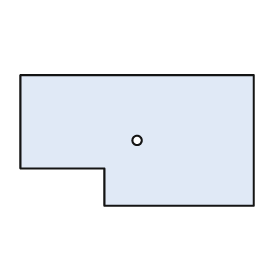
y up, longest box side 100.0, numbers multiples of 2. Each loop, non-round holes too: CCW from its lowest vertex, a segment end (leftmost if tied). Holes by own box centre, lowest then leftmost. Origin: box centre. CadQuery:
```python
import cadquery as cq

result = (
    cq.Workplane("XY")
    .moveTo(-14.0, -28.0)
    .lineTo(50.0, -28.0)
    .lineTo(50.0, 28.0)
    .lineTo(-50.0, 28.0)
    .lineTo(-50.0, -12.0)
    .lineTo(-14.0, -12.0)
    .close()
    .moveTo(0.0, 0.0)
    .circle(2.0)
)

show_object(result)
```